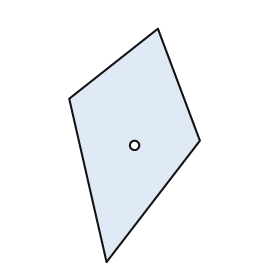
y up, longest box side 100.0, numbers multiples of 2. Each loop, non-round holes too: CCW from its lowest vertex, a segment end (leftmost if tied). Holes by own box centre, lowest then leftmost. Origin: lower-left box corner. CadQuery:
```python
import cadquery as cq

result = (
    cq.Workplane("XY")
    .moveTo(16.0, 0.0)
    .lineTo(56.0, 52.0)
    .lineTo(38.0, 100.0)
    .lineTo(0.0, 70.0)
    .close()
    .moveTo(28.0, 50.0)
    .circle(2.0)
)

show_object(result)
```